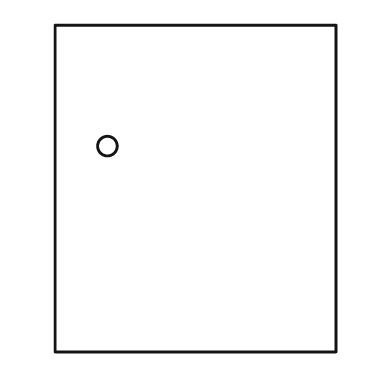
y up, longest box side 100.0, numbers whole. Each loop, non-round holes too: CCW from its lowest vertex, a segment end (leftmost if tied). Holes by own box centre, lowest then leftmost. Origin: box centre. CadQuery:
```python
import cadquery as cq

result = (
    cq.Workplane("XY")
    .moveTo(-43.0, -50.0)
    .lineTo(43.0, -50.0)
    .lineTo(43.0, 50.0)
    .lineTo(-43.0, 50.0)
    .close()
    .moveTo(-27.0, 13.0)
    .circle(3.0)
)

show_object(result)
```